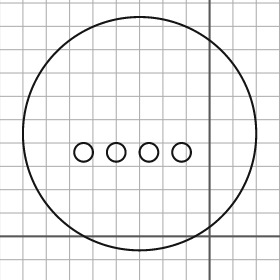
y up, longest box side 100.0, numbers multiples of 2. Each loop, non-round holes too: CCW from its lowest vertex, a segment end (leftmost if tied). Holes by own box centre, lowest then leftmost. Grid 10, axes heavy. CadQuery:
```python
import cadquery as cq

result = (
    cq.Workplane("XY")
    .moveTo(-30.0, 44.0)
    .circle(50.0)
    .moveTo(-54.0, 36.0)
    .circle(4.0)
    .moveTo(-40.0, 36.0)
    .circle(4.0)
    .moveTo(-26.0, 36.0)
    .circle(4.0)
    .moveTo(-12.0, 36.0)
    .circle(4.0)
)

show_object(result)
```